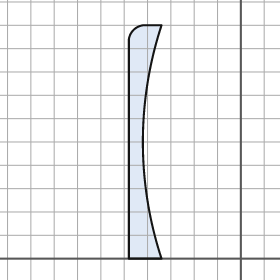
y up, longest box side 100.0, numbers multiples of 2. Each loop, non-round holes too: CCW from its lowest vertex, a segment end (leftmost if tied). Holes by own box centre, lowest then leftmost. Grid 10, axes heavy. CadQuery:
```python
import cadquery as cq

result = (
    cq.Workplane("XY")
    .moveTo(-48.0, 0.0)
    .lineTo(-34.0, 0.0)
    .threePointArc((-42.0, 50.0), (-34.0, 100.0))
    .lineTo(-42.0, 100.0)
    .threePointArc((-46.0, 98.0), (-48.0, 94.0))
    .close()
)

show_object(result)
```